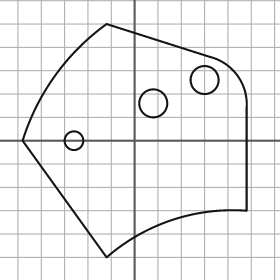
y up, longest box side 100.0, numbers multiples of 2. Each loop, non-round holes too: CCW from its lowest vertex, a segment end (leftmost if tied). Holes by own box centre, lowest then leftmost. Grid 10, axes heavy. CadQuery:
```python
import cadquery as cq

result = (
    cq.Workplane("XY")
    .moveTo(-12.0, -50.0)
    .threePointArc((16.0, -34.0), (48.0, -30.0))
    .lineTo(48.0, 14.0)
    .threePointArc((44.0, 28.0), (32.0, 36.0))
    .lineTo(-12.0, 50.0)
    .threePointArc((-34.0, 28.0), (-48.0, 0.0))
    .close()
    .moveTo(-26.0, 0.0)
    .circle(4.0)
    .moveTo(8.0, 16.0)
    .circle(6.0)
    .moveTo(30.0, 26.0)
    .circle(6.0)
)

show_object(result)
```